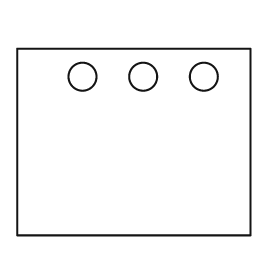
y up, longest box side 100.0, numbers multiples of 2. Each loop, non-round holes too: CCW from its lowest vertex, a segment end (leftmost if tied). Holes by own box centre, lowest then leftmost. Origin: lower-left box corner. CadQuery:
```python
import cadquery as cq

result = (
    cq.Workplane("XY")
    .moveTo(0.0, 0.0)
    .lineTo(100.0, 0.0)
    .lineTo(100.0, 80.0)
    .lineTo(0.0, 80.0)
    .close()
    .moveTo(28.0, 68.0)
    .circle(6.0)
    .moveTo(54.0, 68.0)
    .circle(6.0)
    .moveTo(80.0, 68.0)
    .circle(6.0)
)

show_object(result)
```